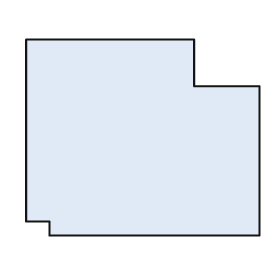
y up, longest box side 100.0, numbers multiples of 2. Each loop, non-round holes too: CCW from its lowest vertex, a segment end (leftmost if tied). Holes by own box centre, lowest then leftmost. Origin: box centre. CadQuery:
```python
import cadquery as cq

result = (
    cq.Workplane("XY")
    .moveTo(-40.0, -42.0)
    .lineTo(50.0, -42.0)
    .lineTo(50.0, 22.0)
    .lineTo(22.0, 22.0)
    .lineTo(22.0, 42.0)
    .lineTo(-50.0, 42.0)
    .lineTo(-50.0, -36.0)
    .lineTo(-40.0, -36.0)
    .close()
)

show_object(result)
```